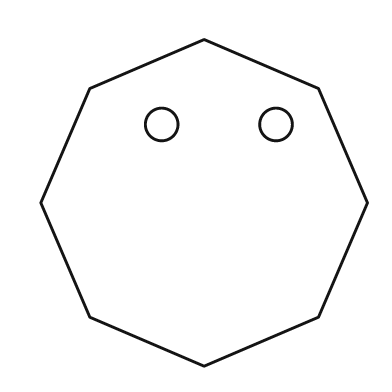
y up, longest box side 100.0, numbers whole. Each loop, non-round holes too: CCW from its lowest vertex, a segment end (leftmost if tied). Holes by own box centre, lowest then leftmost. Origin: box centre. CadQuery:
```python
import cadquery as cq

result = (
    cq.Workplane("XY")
    .moveTo(0.0, -50.0)
    .lineTo(35.0, -35.0)
    .lineTo(50.0, 0.0)
    .lineTo(35.0, 35.0)
    .lineTo(0.0, 50.0)
    .lineTo(-35.0, 35.0)
    .lineTo(-50.0, 0.0)
    .lineTo(-35.0, -35.0)
    .close()
    .moveTo(-13.0, 24.0)
    .circle(5.0)
    .moveTo(22.0, 24.0)
    .circle(5.0)
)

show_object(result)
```